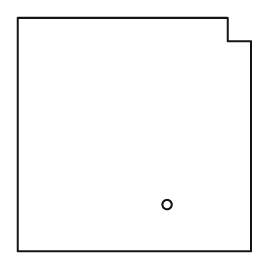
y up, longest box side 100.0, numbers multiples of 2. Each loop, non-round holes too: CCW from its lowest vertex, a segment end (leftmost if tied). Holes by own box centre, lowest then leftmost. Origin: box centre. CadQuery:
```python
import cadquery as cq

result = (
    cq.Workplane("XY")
    .moveTo(-50.0, -50.0)
    .lineTo(50.0, -50.0)
    .lineTo(50.0, 40.0)
    .lineTo(40.0, 40.0)
    .lineTo(40.0, 50.0)
    .lineTo(-50.0, 50.0)
    .close()
    .moveTo(14.0, -30.0)
    .circle(2.0)
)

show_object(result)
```